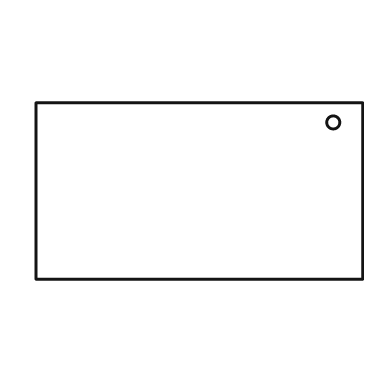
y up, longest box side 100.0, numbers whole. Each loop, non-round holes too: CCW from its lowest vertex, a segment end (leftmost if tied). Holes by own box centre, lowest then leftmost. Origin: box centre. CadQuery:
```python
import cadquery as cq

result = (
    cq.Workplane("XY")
    .moveTo(-50.0, -27.0)
    .lineTo(50.0, -27.0)
    .lineTo(50.0, 27.0)
    .lineTo(-50.0, 27.0)
    .close()
    .moveTo(41.0, 21.0)
    .circle(2.0)
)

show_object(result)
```